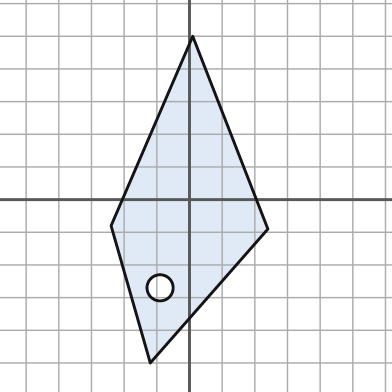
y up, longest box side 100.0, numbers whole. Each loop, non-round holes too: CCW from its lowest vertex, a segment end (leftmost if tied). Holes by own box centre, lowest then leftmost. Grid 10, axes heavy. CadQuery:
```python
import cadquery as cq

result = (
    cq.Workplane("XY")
    .moveTo(-12.0, -50.0)
    .lineTo(24.0, -9.0)
    .lineTo(1.0, 50.0)
    .lineTo(-24.0, -8.0)
    .close()
    .moveTo(-9.0, -27.0)
    .circle(4.0)
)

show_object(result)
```